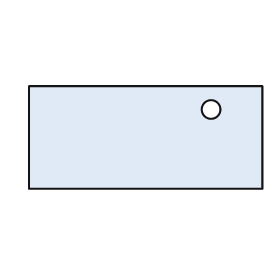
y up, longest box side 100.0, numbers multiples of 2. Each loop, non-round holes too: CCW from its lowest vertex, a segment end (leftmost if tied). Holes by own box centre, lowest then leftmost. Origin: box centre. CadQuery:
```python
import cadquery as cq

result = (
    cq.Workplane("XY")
    .moveTo(-50.0, -22.0)
    .lineTo(50.0, -22.0)
    .lineTo(50.0, 22.0)
    .lineTo(-50.0, 22.0)
    .close()
    .moveTo(28.0, 12.0)
    .circle(4.0)
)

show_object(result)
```